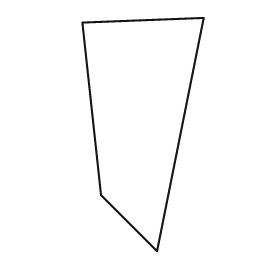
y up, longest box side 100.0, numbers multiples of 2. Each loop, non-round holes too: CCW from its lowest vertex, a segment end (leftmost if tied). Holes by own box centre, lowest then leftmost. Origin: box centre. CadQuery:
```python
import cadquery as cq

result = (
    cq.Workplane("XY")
    .moveTo(6.0, -50.0)
    .lineTo(26.0, 50.0)
    .lineTo(-26.0, 48.0)
    .lineTo(-18.0, -26.0)
    .close()
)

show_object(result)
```